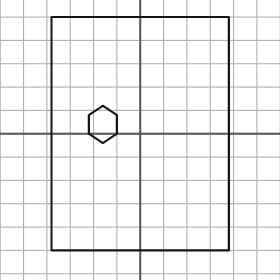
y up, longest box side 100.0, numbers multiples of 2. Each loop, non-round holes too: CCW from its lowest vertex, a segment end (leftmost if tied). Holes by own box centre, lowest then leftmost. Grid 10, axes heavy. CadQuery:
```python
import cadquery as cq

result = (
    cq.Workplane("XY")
    .moveTo(-38.0, -50.0)
    .lineTo(38.0, -50.0)
    .lineTo(38.0, 50.0)
    .lineTo(-38.0, 50.0)
    .close()
    .moveTo(-16.0, -4.0)
    .lineTo(-10.0, 0.0)
    .lineTo(-10.0, 8.0)
    .lineTo(-16.0, 12.0)
    .lineTo(-22.0, 8.0)
    .lineTo(-22.0, 0.0)
    .close()
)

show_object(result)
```